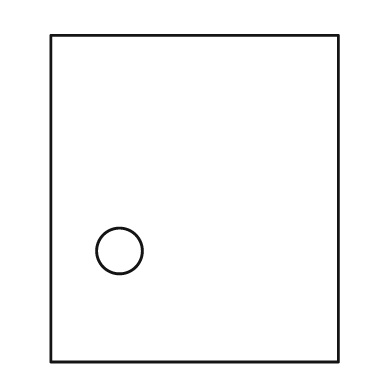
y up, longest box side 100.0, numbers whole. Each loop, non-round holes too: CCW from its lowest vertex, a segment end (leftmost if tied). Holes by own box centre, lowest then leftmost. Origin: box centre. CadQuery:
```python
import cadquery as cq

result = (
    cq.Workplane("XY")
    .moveTo(-44.0, -50.0)
    .lineTo(44.0, -50.0)
    .lineTo(44.0, 50.0)
    .lineTo(-44.0, 50.0)
    .close()
    .moveTo(-23.0, -16.0)
    .circle(7.0)
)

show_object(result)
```